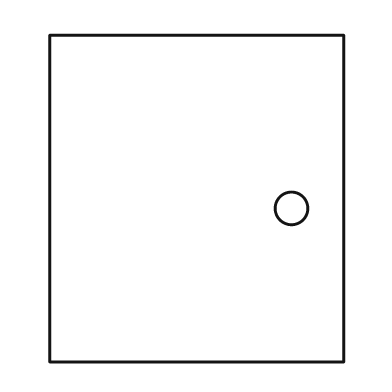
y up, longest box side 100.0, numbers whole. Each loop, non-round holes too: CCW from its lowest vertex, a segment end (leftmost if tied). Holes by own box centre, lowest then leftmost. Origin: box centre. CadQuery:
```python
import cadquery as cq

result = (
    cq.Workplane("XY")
    .moveTo(-45.0, -50.0)
    .lineTo(45.0, -50.0)
    .lineTo(45.0, 50.0)
    .lineTo(-45.0, 50.0)
    .close()
    .moveTo(29.0, -3.0)
    .circle(5.0)
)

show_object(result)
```